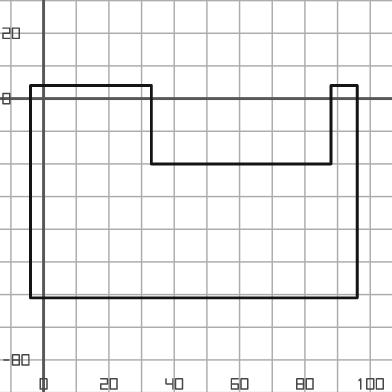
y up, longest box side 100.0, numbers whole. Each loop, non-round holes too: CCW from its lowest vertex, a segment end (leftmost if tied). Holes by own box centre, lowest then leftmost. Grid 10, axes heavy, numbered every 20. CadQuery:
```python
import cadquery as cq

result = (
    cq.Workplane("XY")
    .moveTo(-4.0, -61.0)
    .lineTo(96.0, -61.0)
    .lineTo(96.0, 4.0)
    .lineTo(88.0, 4.0)
    .lineTo(88.0, -20.0)
    .lineTo(33.0, -20.0)
    .lineTo(33.0, 4.0)
    .lineTo(-4.0, 4.0)
    .close()
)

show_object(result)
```